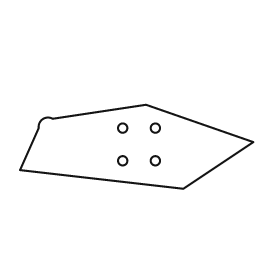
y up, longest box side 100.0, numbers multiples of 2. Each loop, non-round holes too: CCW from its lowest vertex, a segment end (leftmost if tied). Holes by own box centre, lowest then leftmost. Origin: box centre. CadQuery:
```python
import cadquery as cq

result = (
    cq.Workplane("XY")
    .moveTo(20.0, -18.0)
    .lineTo(50.0, 2.0)
    .lineTo(4.0, 18.0)
    .lineTo(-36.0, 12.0)
    .threePointArc((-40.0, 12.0), (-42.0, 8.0))
    .lineTo(-50.0, -10.0)
    .close()
    .moveTo(-6.0, -6.0)
    .circle(2.0)
    .moveTo(8.0, -6.0)
    .circle(2.0)
    .moveTo(-6.0, 8.0)
    .circle(2.0)
    .moveTo(8.0, 8.0)
    .circle(2.0)
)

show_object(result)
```